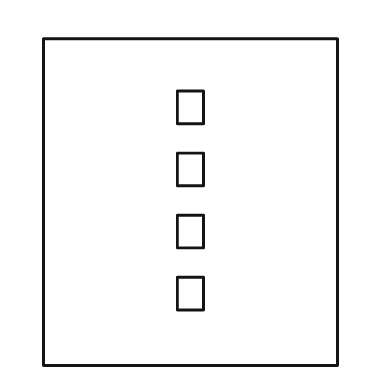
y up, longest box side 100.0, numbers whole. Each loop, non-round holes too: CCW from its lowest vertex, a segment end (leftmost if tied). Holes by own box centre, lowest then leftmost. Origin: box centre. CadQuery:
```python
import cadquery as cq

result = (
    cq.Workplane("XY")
    .moveTo(-45.0, -50.0)
    .lineTo(45.0, -50.0)
    .lineTo(45.0, 50.0)
    .lineTo(-45.0, 50.0)
    .close()
    .moveTo(-4.0, -33.0)
    .lineTo(4.0, -33.0)
    .lineTo(4.0, -23.0)
    .lineTo(-4.0, -23.0)
    .close()
    .moveTo(-4.0, -14.0)
    .lineTo(4.0, -14.0)
    .lineTo(4.0, -4.0)
    .lineTo(-4.0, -4.0)
    .close()
    .moveTo(-4.0, 5.0)
    .lineTo(4.0, 5.0)
    .lineTo(4.0, 15.0)
    .lineTo(-4.0, 15.0)
    .close()
    .moveTo(-4.0, 24.0)
    .lineTo(4.0, 24.0)
    .lineTo(4.0, 34.0)
    .lineTo(-4.0, 34.0)
    .close()
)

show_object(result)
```